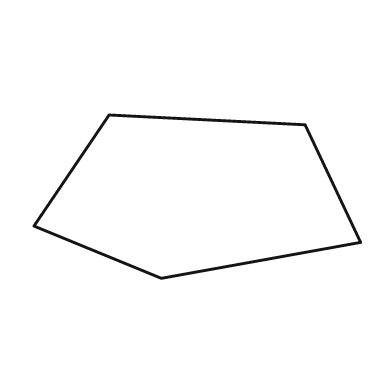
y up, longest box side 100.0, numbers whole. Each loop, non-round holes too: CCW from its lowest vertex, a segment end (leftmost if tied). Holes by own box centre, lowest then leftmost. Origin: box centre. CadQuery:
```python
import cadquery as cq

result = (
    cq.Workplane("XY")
    .moveTo(-11.0, -25.0)
    .lineTo(50.0, -14.0)
    .lineTo(33.0, 22.0)
    .lineTo(-27.0, 25.0)
    .lineTo(-50.0, -9.0)
    .close()
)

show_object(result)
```